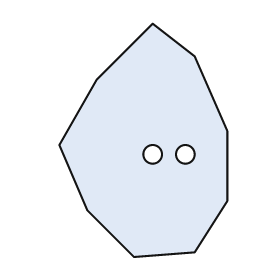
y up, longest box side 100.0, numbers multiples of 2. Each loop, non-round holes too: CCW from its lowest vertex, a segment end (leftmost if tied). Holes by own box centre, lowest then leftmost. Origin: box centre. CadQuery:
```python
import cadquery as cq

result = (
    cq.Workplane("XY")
    .moveTo(-4.0, -50.0)
    .lineTo(22.0, -48.0)
    .lineTo(36.0, -26.0)
    .lineTo(36.0, 4.0)
    .lineTo(22.0, 36.0)
    .lineTo(4.0, 50.0)
    .lineTo(-20.0, 26.0)
    .lineTo(-36.0, -2.0)
    .lineTo(-24.0, -30.0)
    .close()
    .moveTo(4.0, -6.0)
    .circle(4.0)
    .moveTo(18.0, -6.0)
    .circle(4.0)
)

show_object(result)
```